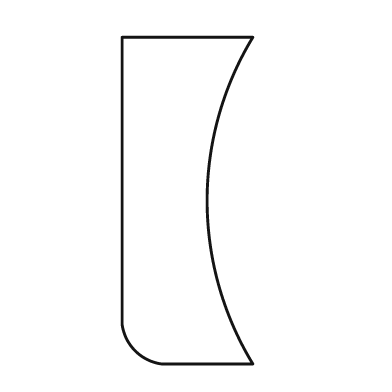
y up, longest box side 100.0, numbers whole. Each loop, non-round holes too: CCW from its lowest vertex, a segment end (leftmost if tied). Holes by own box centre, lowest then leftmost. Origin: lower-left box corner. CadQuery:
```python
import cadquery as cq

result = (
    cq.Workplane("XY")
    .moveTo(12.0, 0.0)
    .lineTo(40.0, 0.0)
    .threePointArc((26.0, 50.0), (40.0, 100.0))
    .lineTo(0.0, 100.0)
    .lineTo(0.0, 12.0)
    .threePointArc((4.0, 4.0), (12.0, 0.0))
    .close()
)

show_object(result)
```